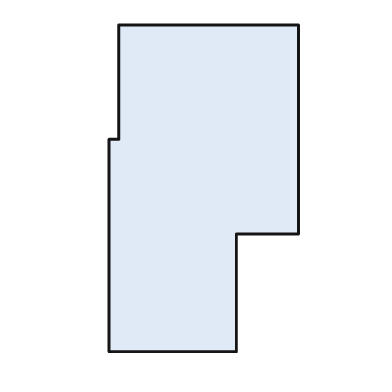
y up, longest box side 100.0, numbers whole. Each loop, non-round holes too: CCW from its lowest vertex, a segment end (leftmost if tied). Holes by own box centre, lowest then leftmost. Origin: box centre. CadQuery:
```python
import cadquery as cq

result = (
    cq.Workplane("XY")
    .moveTo(-29.0, -50.0)
    .lineTo(10.0, -50.0)
    .lineTo(10.0, -14.0)
    .lineTo(29.0, -14.0)
    .lineTo(29.0, 50.0)
    .lineTo(-26.0, 50.0)
    .lineTo(-26.0, 15.0)
    .lineTo(-29.0, 15.0)
    .close()
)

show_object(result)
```